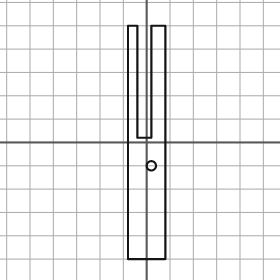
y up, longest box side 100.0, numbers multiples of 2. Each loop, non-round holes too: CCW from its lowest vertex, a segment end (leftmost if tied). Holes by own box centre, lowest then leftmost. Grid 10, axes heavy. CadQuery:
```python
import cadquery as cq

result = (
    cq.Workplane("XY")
    .moveTo(-8.0, -50.0)
    .lineTo(8.0, -50.0)
    .lineTo(8.0, 50.0)
    .lineTo(2.0, 50.0)
    .lineTo(2.0, 2.0)
    .lineTo(-4.0, 2.0)
    .lineTo(-4.0, 50.0)
    .lineTo(-8.0, 50.0)
    .close()
    .moveTo(2.0, -10.0)
    .circle(2.0)
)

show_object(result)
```